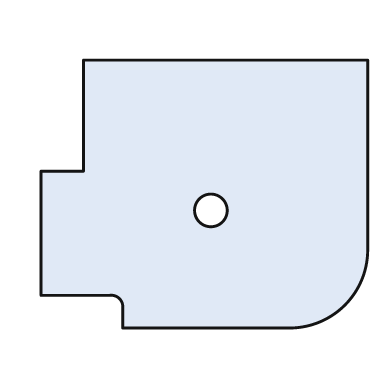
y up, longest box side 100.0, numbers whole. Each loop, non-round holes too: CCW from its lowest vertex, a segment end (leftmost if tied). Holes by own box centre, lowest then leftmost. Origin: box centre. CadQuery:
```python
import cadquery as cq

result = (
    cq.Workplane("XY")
    .moveTo(-25.0, -41.0)
    .lineTo(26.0, -41.0)
    .threePointArc((43.0, -34.0), (50.0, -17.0))
    .lineTo(50.0, 41.0)
    .lineTo(-37.0, 41.0)
    .lineTo(-37.0, 7.0)
    .lineTo(-50.0, 7.0)
    .lineTo(-50.0, -31.0)
    .lineTo(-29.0, -31.0)
    .threePointArc((-26.0, -32.0), (-25.0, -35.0))
    .close()
    .moveTo(2.0, -5.0)
    .circle(5.0)
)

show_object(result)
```